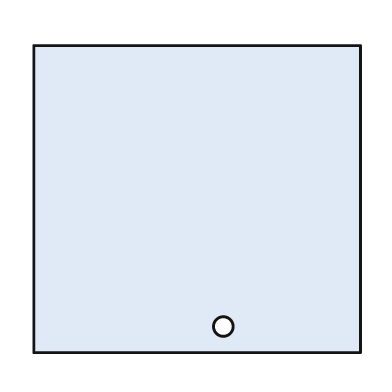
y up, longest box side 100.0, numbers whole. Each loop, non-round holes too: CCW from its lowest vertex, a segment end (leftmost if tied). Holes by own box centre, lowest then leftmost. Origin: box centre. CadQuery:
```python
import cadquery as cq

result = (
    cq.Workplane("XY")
    .moveTo(-50.0, -47.0)
    .lineTo(50.0, -47.0)
    .lineTo(50.0, 47.0)
    .lineTo(-50.0, 47.0)
    .close()
    .moveTo(8.0, -39.0)
    .circle(3.0)
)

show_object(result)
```